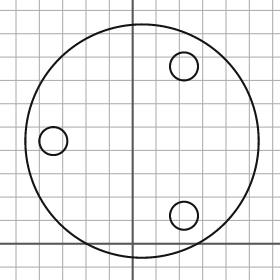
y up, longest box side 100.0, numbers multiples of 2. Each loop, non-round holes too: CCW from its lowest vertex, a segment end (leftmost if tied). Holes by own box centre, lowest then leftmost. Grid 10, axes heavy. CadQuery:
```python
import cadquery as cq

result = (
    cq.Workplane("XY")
    .moveTo(4.0, 44.0)
    .circle(50.0)
    .moveTo(22.0, 12.0)
    .circle(6.0)
    .moveTo(-34.0, 44.0)
    .circle(6.0)
    .moveTo(22.0, 76.0)
    .circle(6.0)
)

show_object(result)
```